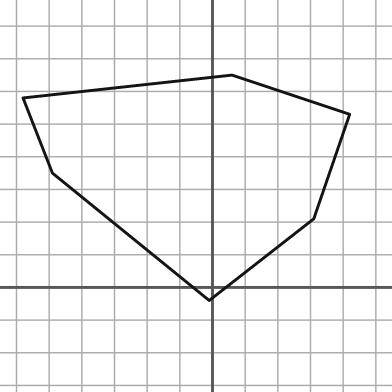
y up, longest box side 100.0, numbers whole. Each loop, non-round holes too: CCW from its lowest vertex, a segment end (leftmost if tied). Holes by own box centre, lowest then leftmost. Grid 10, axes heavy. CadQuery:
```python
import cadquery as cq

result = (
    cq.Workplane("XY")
    .moveTo(-1.0, -4.0)
    .lineTo(31.0, 21.0)
    .lineTo(42.0, 53.0)
    .lineTo(6.0, 65.0)
    .lineTo(-58.0, 58.0)
    .lineTo(-49.0, 35.0)
    .close()
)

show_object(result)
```